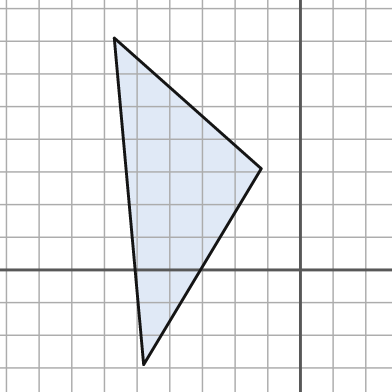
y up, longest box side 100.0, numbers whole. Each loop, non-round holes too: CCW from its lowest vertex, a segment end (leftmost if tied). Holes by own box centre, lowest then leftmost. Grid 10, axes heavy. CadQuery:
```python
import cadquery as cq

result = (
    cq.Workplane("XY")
    .moveTo(-48.0, -29.0)
    .lineTo(-12.0, 31.0)
    .lineTo(-57.0, 71.0)
    .close()
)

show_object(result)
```